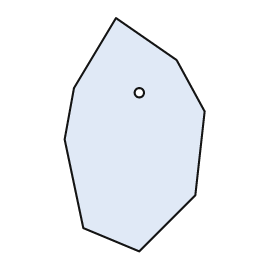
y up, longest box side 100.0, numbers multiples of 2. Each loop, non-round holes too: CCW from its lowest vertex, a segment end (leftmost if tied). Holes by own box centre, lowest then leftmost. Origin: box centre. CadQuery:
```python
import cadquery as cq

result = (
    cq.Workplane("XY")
    .moveTo(2.0, -50.0)
    .lineTo(26.0, -26.0)
    .lineTo(30.0, 10.0)
    .lineTo(18.0, 32.0)
    .lineTo(-8.0, 50.0)
    .lineTo(-26.0, 20.0)
    .lineTo(-30.0, -2.0)
    .lineTo(-22.0, -40.0)
    .close()
    .moveTo(2.0, 18.0)
    .circle(2.0)
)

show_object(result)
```